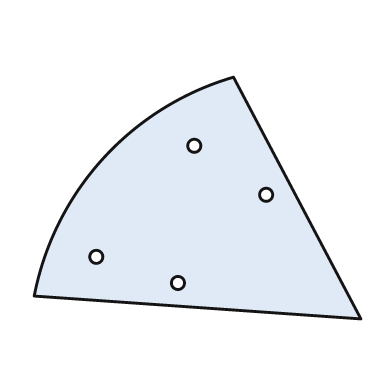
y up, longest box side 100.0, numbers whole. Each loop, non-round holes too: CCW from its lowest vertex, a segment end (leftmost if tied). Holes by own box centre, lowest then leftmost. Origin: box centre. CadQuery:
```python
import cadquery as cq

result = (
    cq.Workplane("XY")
    .moveTo(50.0, -37.0)
    .lineTo(11.0, 37.0)
    .threePointArc((-29.0, 12.0), (-50.0, -30.0))
    .close()
    .moveTo(-6.0, -26.0)
    .circle(2.0)
    .moveTo(-31.0, -18.0)
    .circle(2.0)
    .moveTo(21.0, 1.0)
    .circle(2.0)
    .moveTo(-1.0, 16.0)
    .circle(2.0)
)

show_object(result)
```